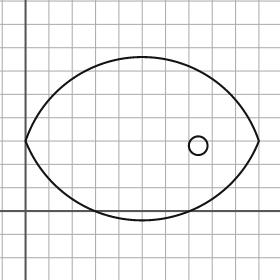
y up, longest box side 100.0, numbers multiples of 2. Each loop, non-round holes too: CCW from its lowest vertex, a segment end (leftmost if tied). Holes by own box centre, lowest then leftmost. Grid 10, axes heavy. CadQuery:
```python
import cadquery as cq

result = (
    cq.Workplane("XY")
    .moveTo(0.0, 30.0)
    .threePointArc((50.0, -4.0), (100.0, 30.0))
    .threePointArc((50.0, 66.0), (0.0, 30.0))
    .close()
    .moveTo(74.0, 28.0)
    .circle(4.0)
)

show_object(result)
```